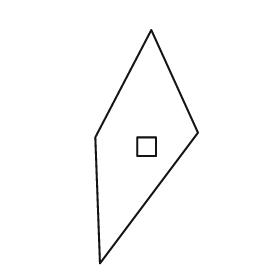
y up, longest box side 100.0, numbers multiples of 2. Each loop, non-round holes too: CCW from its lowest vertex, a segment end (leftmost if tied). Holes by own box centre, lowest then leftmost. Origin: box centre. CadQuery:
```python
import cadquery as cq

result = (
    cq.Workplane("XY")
    .moveTo(-20.0, -50.0)
    .lineTo(22.0, 6.0)
    .lineTo(2.0, 50.0)
    .lineTo(-22.0, 4.0)
    .close()
    .moveTo(-4.0, -4.0)
    .lineTo(4.0, -4.0)
    .lineTo(4.0, 4.0)
    .lineTo(-4.0, 4.0)
    .close()
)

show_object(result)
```